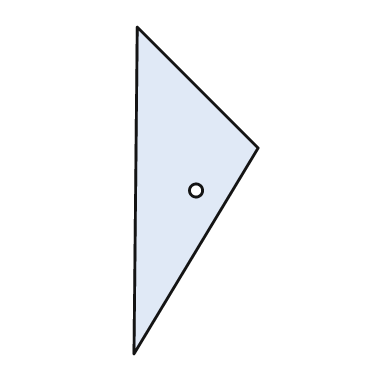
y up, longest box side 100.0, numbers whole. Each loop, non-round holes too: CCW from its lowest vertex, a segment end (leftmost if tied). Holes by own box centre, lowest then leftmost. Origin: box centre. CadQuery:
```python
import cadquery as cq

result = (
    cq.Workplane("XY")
    .moveTo(-19.0, -50.0)
    .lineTo(19.0, 13.0)
    .lineTo(-18.0, 50.0)
    .close()
    .moveTo(0.0, 0.0)
    .circle(2.0)
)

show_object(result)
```